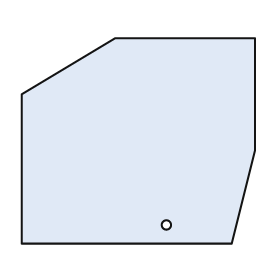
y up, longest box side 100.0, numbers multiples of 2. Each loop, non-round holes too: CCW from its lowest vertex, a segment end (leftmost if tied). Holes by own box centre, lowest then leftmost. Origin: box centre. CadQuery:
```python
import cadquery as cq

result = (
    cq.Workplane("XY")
    .moveTo(-50.0, -44.0)
    .lineTo(40.0, -44.0)
    .lineTo(50.0, -4.0)
    .lineTo(50.0, 44.0)
    .lineTo(-10.0, 44.0)
    .lineTo(-50.0, 20.0)
    .close()
    .moveTo(12.0, -36.0)
    .circle(2.0)
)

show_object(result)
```